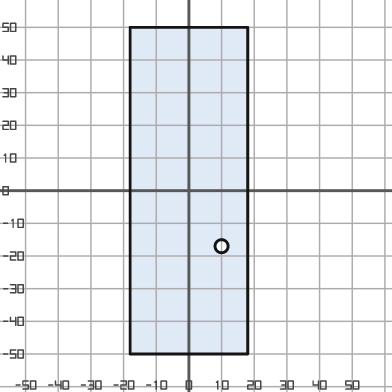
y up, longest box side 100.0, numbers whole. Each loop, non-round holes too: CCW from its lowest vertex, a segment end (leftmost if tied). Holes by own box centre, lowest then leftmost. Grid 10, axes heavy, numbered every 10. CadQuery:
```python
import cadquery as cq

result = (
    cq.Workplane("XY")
    .moveTo(-18.0, -50.0)
    .lineTo(18.0, -50.0)
    .lineTo(18.0, 50.0)
    .lineTo(-18.0, 50.0)
    .close()
    .moveTo(10.0, -17.0)
    .circle(2.0)
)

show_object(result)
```